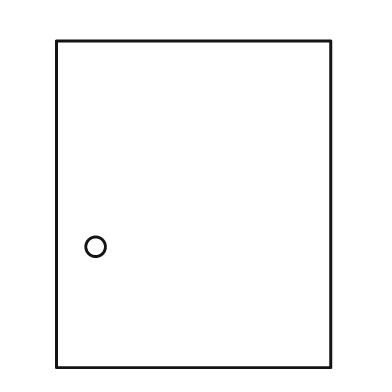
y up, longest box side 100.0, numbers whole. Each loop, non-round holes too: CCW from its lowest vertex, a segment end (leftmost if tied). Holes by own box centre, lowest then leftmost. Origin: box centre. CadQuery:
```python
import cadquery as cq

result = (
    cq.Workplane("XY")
    .moveTo(-42.0, -50.0)
    .lineTo(42.0, -50.0)
    .lineTo(42.0, 50.0)
    .lineTo(-42.0, 50.0)
    .close()
    .moveTo(-30.0, -13.0)
    .circle(3.0)
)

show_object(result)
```